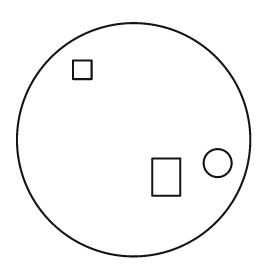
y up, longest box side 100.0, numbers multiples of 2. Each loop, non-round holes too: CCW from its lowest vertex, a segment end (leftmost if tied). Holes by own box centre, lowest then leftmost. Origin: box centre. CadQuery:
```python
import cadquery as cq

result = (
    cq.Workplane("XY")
    .moveTo(0.0, 0.0)
    .circle(50.0)
    .moveTo(8.0, -24.0)
    .lineTo(20.0, -24.0)
    .lineTo(20.0, -8.0)
    .lineTo(8.0, -8.0)
    .close()
    .moveTo(36.0, -10.0)
    .circle(6.0)
    .moveTo(-26.0, 26.0)
    .lineTo(-18.0, 26.0)
    .lineTo(-18.0, 34.0)
    .lineTo(-26.0, 34.0)
    .close()
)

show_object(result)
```